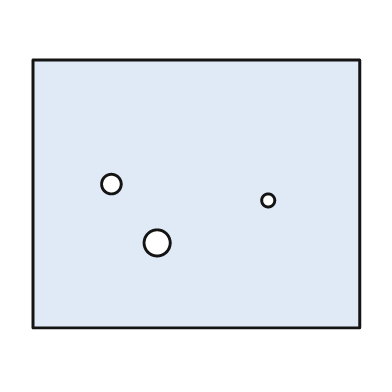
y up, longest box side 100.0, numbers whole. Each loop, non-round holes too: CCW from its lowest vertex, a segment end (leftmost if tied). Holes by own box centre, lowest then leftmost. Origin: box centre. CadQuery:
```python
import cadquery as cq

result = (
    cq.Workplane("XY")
    .moveTo(-50.0, -41.0)
    .lineTo(50.0, -41.0)
    .lineTo(50.0, 41.0)
    .lineTo(-50.0, 41.0)
    .close()
    .moveTo(-12.0, -15.0)
    .circle(4.0)
    .moveTo(22.0, -2.0)
    .circle(2.0)
    .moveTo(-26.0, 3.0)
    .circle(3.0)
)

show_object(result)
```